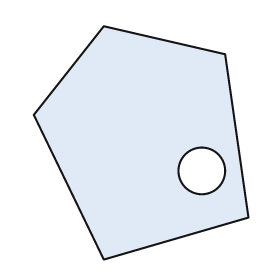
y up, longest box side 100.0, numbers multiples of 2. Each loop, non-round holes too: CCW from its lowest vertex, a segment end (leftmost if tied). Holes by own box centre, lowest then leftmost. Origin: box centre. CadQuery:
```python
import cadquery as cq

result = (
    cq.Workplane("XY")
    .moveTo(-16.0, -50.0)
    .lineTo(46.0, -32.0)
    .lineTo(36.0, 38.0)
    .lineTo(-16.0, 50.0)
    .lineTo(-46.0, 12.0)
    .close()
    .moveTo(26.0, -12.0)
    .circle(10.0)
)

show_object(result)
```